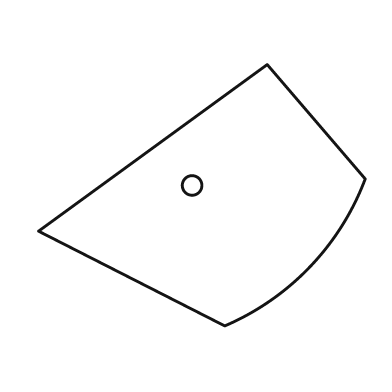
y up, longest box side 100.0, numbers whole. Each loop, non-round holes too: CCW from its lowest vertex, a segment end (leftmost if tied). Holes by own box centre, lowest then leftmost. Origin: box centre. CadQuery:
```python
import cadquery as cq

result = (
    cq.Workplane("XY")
    .moveTo(7.0, -40.0)
    .threePointArc((33.0, -22.0), (50.0, 5.0))
    .lineTo(20.0, 40.0)
    .lineTo(-50.0, -11.0)
    .close()
    .moveTo(-3.0, 3.0)
    .circle(3.0)
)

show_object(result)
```